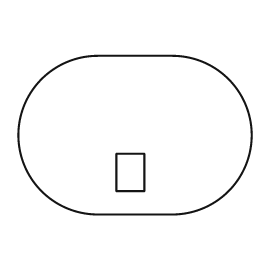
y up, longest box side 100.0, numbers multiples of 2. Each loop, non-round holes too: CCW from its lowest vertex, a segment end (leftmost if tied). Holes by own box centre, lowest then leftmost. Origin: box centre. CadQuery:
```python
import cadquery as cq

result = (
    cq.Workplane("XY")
    .moveTo(-16.0, -34.0)
    .lineTo(16.0, -34.0)
    .threePointArc((50.0, 0.0), (16.0, 34.0))
    .lineTo(-16.0, 34.0)
    .threePointArc((-50.0, 0.0), (-16.0, -34.0))
    .close()
    .moveTo(-8.0, -24.0)
    .lineTo(4.0, -24.0)
    .lineTo(4.0, -8.0)
    .lineTo(-8.0, -8.0)
    .close()
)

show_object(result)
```